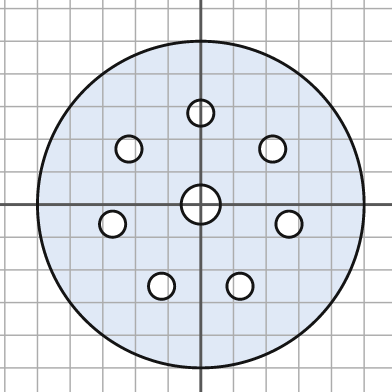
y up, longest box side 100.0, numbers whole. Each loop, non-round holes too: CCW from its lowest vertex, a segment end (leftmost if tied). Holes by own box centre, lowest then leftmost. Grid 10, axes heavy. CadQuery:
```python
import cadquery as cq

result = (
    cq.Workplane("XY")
    .moveTo(0.0, 0.0)
    .circle(50.0)
    .moveTo(-12.0, -25.0)
    .circle(4.0)
    .moveTo(12.0, -25.0)
    .circle(4.0)
    .moveTo(-27.0, -6.0)
    .circle(4.0)
    .moveTo(27.0, -6.0)
    .circle(4.0)
    .moveTo(0.0, 0.0)
    .circle(6.0)
    .moveTo(-22.0, 17.0)
    .circle(4.0)
    .moveTo(22.0, 17.0)
    .circle(4.0)
    .moveTo(0.0, 28.0)
    .circle(4.0)
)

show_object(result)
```